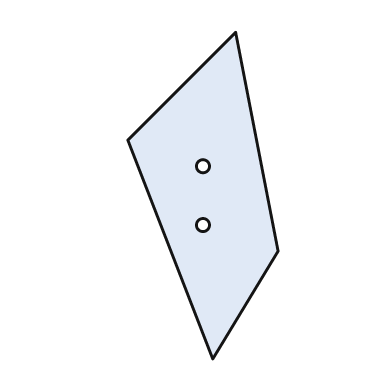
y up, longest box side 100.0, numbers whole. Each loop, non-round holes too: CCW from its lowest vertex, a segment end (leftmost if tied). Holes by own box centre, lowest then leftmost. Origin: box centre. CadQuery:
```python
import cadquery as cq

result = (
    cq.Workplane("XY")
    .moveTo(3.0, -50.0)
    .lineTo(23.0, -17.0)
    .lineTo(10.0, 50.0)
    .lineTo(-23.0, 17.0)
    .close()
    .moveTo(0.0, -9.0)
    .circle(2.0)
    .moveTo(0.0, 9.0)
    .circle(2.0)
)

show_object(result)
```